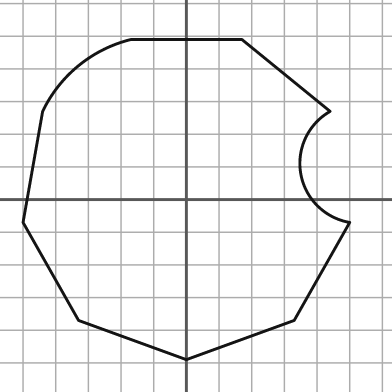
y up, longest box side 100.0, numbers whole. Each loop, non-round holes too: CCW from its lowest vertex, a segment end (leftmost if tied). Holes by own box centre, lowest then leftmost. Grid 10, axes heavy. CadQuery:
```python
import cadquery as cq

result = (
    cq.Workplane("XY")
    .moveTo(0.0, -49.0)
    .lineTo(33.0, -37.0)
    .lineTo(50.0, -7.0)
    .threePointArc((35.0, 8.0), (44.0, 27.0))
    .lineTo(17.0, 49.0)
    .lineTo(-17.0, 49.0)
    .threePointArc((-33.0, 41.0), (-44.0, 27.0))
    .lineTo(-50.0, -7.0)
    .lineTo(-33.0, -37.0)
    .close()
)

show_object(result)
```